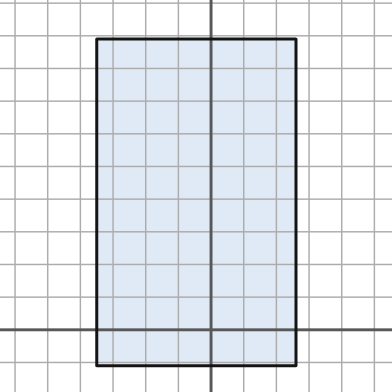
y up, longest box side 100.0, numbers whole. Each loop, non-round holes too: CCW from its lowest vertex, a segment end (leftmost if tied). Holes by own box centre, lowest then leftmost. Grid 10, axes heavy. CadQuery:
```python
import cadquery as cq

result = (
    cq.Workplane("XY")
    .moveTo(-35.0, -11.0)
    .lineTo(26.0, -11.0)
    .lineTo(26.0, 89.0)
    .lineTo(-35.0, 89.0)
    .close()
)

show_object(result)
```